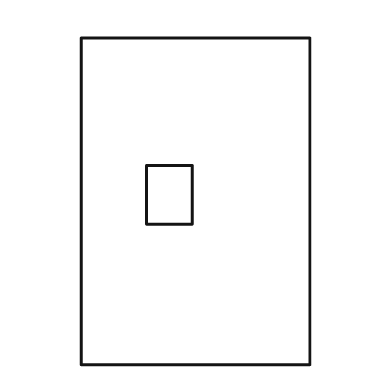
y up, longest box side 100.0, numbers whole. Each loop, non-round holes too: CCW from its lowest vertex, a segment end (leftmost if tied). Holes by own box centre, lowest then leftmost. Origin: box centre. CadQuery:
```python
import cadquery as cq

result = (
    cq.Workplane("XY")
    .moveTo(-35.0, -50.0)
    .lineTo(35.0, -50.0)
    .lineTo(35.0, 50.0)
    .lineTo(-35.0, 50.0)
    .close()
    .moveTo(-15.0, -7.0)
    .lineTo(-1.0, -7.0)
    .lineTo(-1.0, 11.0)
    .lineTo(-15.0, 11.0)
    .close()
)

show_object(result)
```